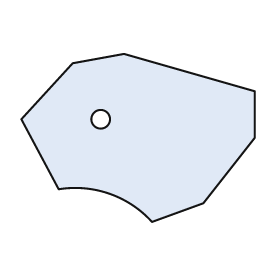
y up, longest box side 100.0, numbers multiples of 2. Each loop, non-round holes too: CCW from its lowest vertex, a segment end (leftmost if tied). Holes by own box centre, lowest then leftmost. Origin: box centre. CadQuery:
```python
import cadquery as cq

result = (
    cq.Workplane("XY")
    .moveTo(6.0, -36.0)
    .lineTo(28.0, -28.0)
    .lineTo(50.0, 0.0)
    .lineTo(50.0, 20.0)
    .lineTo(-6.0, 36.0)
    .lineTo(-28.0, 32.0)
    .lineTo(-50.0, 8.0)
    .lineTo(-34.0, -22.0)
    .threePointArc((-12.0, -24.0), (6.0, -36.0))
    .close()
    .moveTo(-16.0, 8.0)
    .circle(4.0)
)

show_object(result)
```